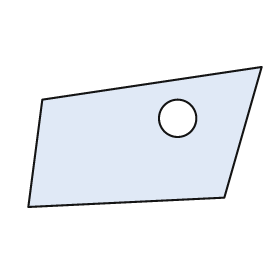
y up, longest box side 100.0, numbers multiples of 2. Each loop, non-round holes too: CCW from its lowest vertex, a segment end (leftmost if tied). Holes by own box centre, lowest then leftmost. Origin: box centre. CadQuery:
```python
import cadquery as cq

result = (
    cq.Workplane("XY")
    .moveTo(-50.0, -30.0)
    .lineTo(34.0, -26.0)
    .lineTo(50.0, 30.0)
    .lineTo(-44.0, 16.0)
    .close()
    .moveTo(14.0, 8.0)
    .circle(8.0)
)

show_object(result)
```